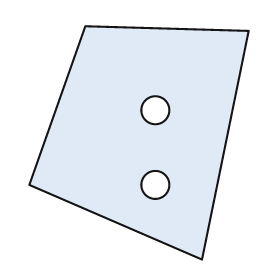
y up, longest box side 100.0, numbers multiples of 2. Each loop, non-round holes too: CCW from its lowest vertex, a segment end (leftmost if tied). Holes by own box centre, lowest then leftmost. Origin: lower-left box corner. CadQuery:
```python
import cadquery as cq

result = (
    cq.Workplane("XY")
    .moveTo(74.0, 0.0)
    .lineTo(94.0, 98.0)
    .lineTo(24.0, 100.0)
    .lineTo(0.0, 32.0)
    .close()
    .moveTo(54.0, 32.0)
    .circle(6.0)
    .moveTo(54.0, 64.0)
    .circle(6.0)
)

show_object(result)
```